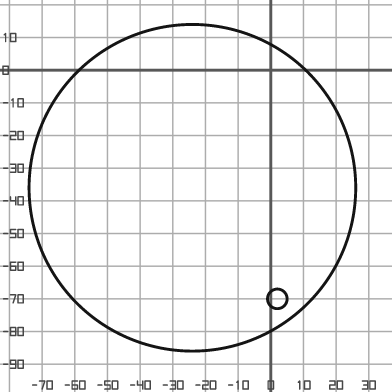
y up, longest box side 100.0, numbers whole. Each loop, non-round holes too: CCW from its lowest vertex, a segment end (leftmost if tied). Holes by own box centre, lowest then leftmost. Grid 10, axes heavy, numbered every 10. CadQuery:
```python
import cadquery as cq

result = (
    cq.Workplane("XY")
    .moveTo(-24.0, -36.0)
    .circle(50.0)
    .moveTo(2.0, -70.0)
    .circle(3.0)
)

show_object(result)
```